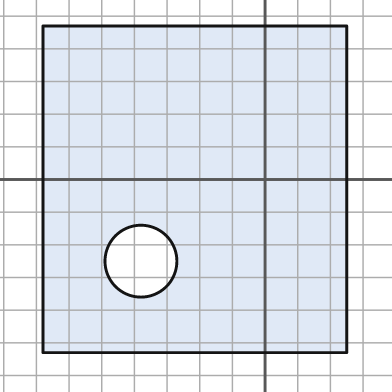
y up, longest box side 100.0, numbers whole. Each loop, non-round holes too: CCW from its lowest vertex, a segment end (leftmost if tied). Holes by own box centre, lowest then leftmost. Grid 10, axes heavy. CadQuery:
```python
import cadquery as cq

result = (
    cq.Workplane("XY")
    .moveTo(-68.0, -53.0)
    .lineTo(25.0, -53.0)
    .lineTo(25.0, 47.0)
    .lineTo(-68.0, 47.0)
    .close()
    .moveTo(-38.0, -25.0)
    .circle(11.0)
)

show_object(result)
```